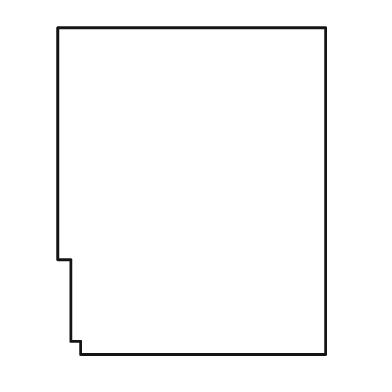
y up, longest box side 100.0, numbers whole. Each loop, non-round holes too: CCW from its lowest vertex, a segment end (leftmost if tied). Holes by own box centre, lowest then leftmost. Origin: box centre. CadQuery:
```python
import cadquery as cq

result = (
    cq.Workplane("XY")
    .moveTo(-34.0, -50.0)
    .lineTo(41.0, -50.0)
    .lineTo(41.0, 50.0)
    .lineTo(-41.0, 50.0)
    .lineTo(-41.0, -21.0)
    .lineTo(-37.0, -21.0)
    .lineTo(-37.0, -46.0)
    .lineTo(-34.0, -46.0)
    .close()
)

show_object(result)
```